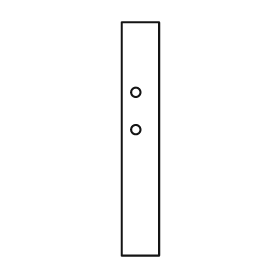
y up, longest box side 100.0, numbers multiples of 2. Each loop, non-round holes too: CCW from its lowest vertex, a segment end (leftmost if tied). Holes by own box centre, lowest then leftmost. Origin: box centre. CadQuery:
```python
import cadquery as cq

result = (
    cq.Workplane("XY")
    .moveTo(-8.0, -50.0)
    .lineTo(8.0, -50.0)
    .lineTo(8.0, 50.0)
    .lineTo(-8.0, 50.0)
    .close()
    .moveTo(-2.0, 4.0)
    .circle(2.0)
    .moveTo(-2.0, 20.0)
    .circle(2.0)
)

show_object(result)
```